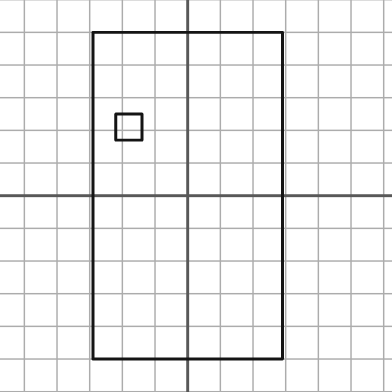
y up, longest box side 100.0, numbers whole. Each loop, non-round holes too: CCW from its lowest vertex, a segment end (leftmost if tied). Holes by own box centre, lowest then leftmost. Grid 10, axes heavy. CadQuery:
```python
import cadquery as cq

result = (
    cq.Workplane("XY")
    .moveTo(-29.0, -50.0)
    .lineTo(29.0, -50.0)
    .lineTo(29.0, 50.0)
    .lineTo(-29.0, 50.0)
    .close()
    .moveTo(-22.0, 17.0)
    .lineTo(-14.0, 17.0)
    .lineTo(-14.0, 25.0)
    .lineTo(-22.0, 25.0)
    .close()
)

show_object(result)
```